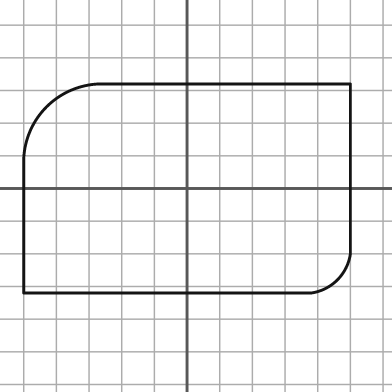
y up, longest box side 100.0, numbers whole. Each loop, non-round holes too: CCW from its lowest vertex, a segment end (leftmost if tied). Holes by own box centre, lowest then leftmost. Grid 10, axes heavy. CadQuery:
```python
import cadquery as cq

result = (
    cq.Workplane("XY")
    .moveTo(-50.0, -32.0)
    .lineTo(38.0, -32.0)
    .threePointArc((46.0, -28.0), (50.0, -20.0))
    .lineTo(50.0, 32.0)
    .lineTo(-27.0, 32.0)
    .threePointArc((-43.0, 25.0), (-50.0, 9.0))
    .close()
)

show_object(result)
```